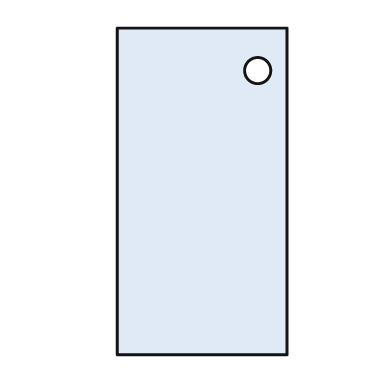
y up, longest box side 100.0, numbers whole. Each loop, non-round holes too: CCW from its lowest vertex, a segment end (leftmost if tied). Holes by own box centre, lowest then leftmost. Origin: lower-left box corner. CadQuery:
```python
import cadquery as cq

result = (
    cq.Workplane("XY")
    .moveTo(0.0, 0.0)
    .lineTo(52.0, 0.0)
    .lineTo(52.0, 100.0)
    .lineTo(0.0, 100.0)
    .close()
    .moveTo(43.0, 87.0)
    .circle(4.0)
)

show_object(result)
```